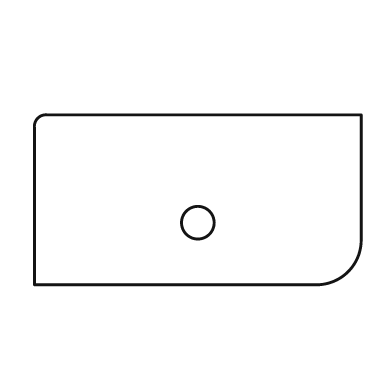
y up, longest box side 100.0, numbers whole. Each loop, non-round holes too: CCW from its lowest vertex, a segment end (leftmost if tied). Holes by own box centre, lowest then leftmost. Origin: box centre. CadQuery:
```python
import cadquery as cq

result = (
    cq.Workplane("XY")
    .moveTo(-50.0, -26.0)
    .lineTo(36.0, -26.0)
    .threePointArc((46.0, -22.0), (50.0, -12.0))
    .lineTo(50.0, 26.0)
    .lineTo(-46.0, 26.0)
    .threePointArc((-49.0, 25.0), (-50.0, 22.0))
    .close()
    .moveTo(0.0, -7.0)
    .circle(5.0)
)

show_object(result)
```